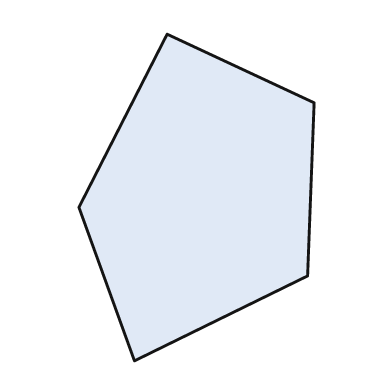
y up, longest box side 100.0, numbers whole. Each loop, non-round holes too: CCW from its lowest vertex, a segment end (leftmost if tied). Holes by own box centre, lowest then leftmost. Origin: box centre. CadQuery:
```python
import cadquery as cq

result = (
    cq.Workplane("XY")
    .moveTo(-19.0, -50.0)
    .lineTo(34.0, -24.0)
    .lineTo(36.0, 29.0)
    .lineTo(-9.0, 50.0)
    .lineTo(-36.0, -3.0)
    .close()
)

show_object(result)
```